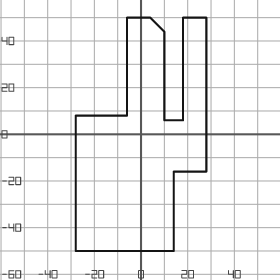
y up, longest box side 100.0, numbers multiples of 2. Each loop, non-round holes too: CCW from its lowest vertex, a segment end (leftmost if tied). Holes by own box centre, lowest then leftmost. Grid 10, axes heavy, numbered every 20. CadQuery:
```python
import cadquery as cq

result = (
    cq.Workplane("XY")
    .moveTo(-28.0, -50.0)
    .lineTo(14.0, -50.0)
    .lineTo(14.0, -16.0)
    .lineTo(28.0, -16.0)
    .lineTo(28.0, 50.0)
    .lineTo(18.0, 50.0)
    .lineTo(18.0, 6.0)
    .lineTo(10.0, 6.0)
    .lineTo(10.0, 44.0)
    .lineTo(4.0, 50.0)
    .lineTo(-6.0, 50.0)
    .lineTo(-6.0, 8.0)
    .lineTo(-28.0, 8.0)
    .close()
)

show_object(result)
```